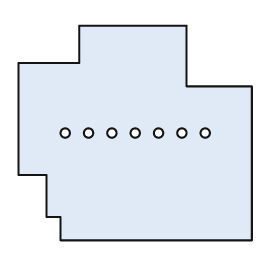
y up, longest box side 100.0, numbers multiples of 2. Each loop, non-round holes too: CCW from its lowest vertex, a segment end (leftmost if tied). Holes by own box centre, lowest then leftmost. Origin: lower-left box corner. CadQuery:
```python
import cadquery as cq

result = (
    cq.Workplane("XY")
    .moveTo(18.0, 0.0)
    .lineTo(100.0, 0.0)
    .lineTo(100.0, 66.0)
    .lineTo(72.0, 66.0)
    .lineTo(72.0, 92.0)
    .lineTo(26.0, 92.0)
    .lineTo(26.0, 76.0)
    .lineTo(0.0, 76.0)
    .lineTo(0.0, 28.0)
    .lineTo(12.0, 28.0)
    .lineTo(12.0, 10.0)
    .lineTo(18.0, 10.0)
    .close()
    .moveTo(20.0, 46.0)
    .circle(2.0)
    .moveTo(30.0, 46.0)
    .circle(2.0)
    .moveTo(40.0, 46.0)
    .circle(2.0)
    .moveTo(50.0, 46.0)
    .circle(2.0)
    .moveTo(60.0, 46.0)
    .circle(2.0)
    .moveTo(70.0, 46.0)
    .circle(2.0)
    .moveTo(80.0, 46.0)
    .circle(2.0)
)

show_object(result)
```